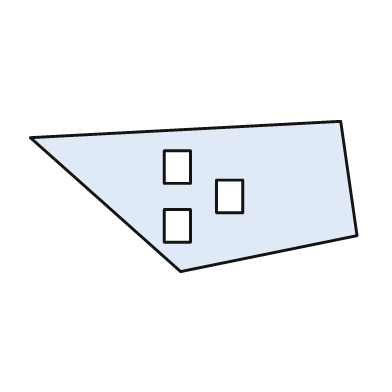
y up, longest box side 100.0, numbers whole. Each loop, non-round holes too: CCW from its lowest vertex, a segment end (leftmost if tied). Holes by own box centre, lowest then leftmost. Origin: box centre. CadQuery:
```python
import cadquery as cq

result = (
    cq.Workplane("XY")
    .moveTo(-4.0, -23.0)
    .lineTo(50.0, -12.0)
    .lineTo(45.0, 23.0)
    .lineTo(-50.0, 18.0)
    .close()
    .moveTo(-9.0, -14.0)
    .lineTo(-1.0, -14.0)
    .lineTo(-1.0, -4.0)
    .lineTo(-9.0, -4.0)
    .close()
    .moveTo(7.0, -5.0)
    .lineTo(15.0, -5.0)
    .lineTo(15.0, 5.0)
    .lineTo(7.0, 5.0)
    .close()
    .moveTo(-9.0, 4.0)
    .lineTo(-1.0, 4.0)
    .lineTo(-1.0, 14.0)
    .lineTo(-9.0, 14.0)
    .close()
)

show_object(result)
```